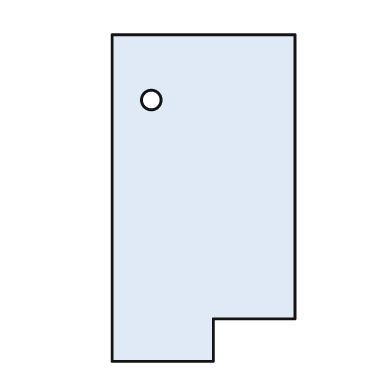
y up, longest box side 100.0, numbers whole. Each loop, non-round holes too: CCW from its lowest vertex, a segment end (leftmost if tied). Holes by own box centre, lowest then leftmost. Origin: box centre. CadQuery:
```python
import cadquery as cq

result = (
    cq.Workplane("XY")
    .moveTo(-28.0, -50.0)
    .lineTo(3.0, -50.0)
    .lineTo(3.0, -37.0)
    .lineTo(28.0, -37.0)
    .lineTo(28.0, 50.0)
    .lineTo(-28.0, 50.0)
    .close()
    .moveTo(-16.0, 30.0)
    .circle(3.0)
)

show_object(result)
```